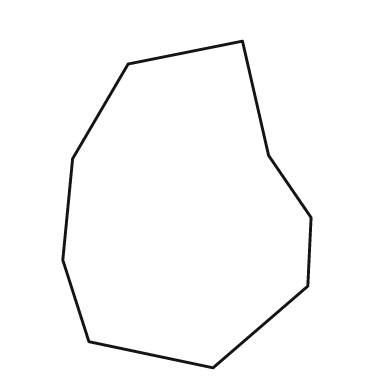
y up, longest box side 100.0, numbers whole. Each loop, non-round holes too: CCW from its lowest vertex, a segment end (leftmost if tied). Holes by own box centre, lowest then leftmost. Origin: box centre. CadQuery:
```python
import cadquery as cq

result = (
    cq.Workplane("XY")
    .moveTo(8.0, -50.0)
    .lineTo(37.0, -25.0)
    .lineTo(38.0, -4.0)
    .lineTo(25.0, 15.0)
    .lineTo(17.0, 50.0)
    .lineTo(-18.0, 43.0)
    .lineTo(-35.0, 14.0)
    .lineTo(-38.0, -17.0)
    .lineTo(-30.0, -42.0)
    .close()
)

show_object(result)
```